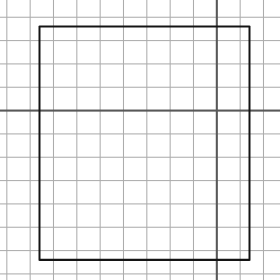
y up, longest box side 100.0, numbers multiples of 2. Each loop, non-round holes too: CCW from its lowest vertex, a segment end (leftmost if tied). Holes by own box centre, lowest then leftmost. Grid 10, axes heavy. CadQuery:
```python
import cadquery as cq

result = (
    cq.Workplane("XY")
    .moveTo(-76.0, -64.0)
    .lineTo(14.0, -64.0)
    .lineTo(14.0, 36.0)
    .lineTo(-76.0, 36.0)
    .close()
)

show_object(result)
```